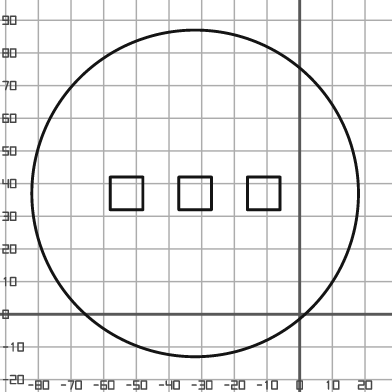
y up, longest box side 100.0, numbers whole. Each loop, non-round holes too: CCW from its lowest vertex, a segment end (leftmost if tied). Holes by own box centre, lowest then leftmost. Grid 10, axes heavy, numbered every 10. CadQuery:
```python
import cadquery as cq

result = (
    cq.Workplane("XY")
    .moveTo(-32.0, 37.0)
    .circle(50.0)
    .moveTo(-58.0, 32.0)
    .lineTo(-48.0, 32.0)
    .lineTo(-48.0, 42.0)
    .lineTo(-58.0, 42.0)
    .close()
    .moveTo(-37.0, 32.0)
    .lineTo(-27.0, 32.0)
    .lineTo(-27.0, 42.0)
    .lineTo(-37.0, 42.0)
    .close()
    .moveTo(-16.0, 32.0)
    .lineTo(-6.0, 32.0)
    .lineTo(-6.0, 42.0)
    .lineTo(-16.0, 42.0)
    .close()
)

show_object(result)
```